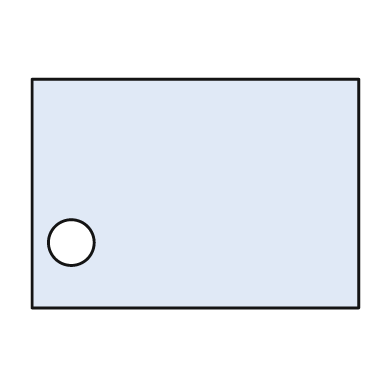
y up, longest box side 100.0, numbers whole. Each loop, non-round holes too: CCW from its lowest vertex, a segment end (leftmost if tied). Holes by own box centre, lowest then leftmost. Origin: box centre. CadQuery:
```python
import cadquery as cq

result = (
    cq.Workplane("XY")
    .moveTo(-50.0, -35.0)
    .lineTo(50.0, -35.0)
    .lineTo(50.0, 35.0)
    .lineTo(-50.0, 35.0)
    .close()
    .moveTo(-38.0, -15.0)
    .circle(7.0)
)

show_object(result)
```